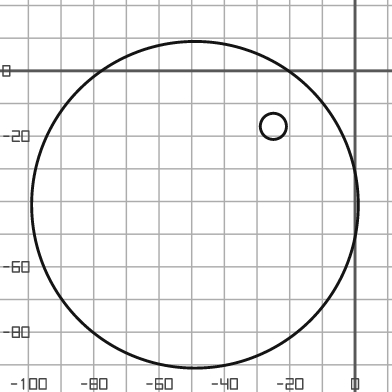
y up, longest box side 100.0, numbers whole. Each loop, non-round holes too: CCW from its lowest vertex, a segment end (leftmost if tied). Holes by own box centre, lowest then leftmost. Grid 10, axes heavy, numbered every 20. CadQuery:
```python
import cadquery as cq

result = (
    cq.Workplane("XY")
    .moveTo(-49.0, -41.0)
    .circle(50.0)
    .moveTo(-25.0, -17.0)
    .circle(4.0)
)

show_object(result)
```